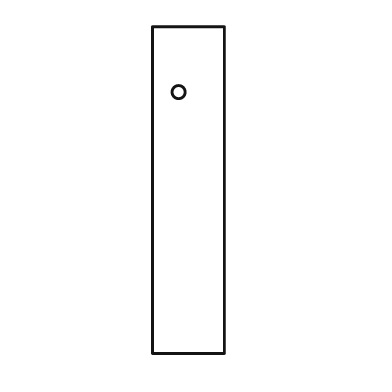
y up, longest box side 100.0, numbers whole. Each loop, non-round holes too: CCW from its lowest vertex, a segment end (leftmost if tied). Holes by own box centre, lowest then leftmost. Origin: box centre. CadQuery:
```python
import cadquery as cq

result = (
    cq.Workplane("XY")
    .moveTo(-11.0, -50.0)
    .lineTo(11.0, -50.0)
    .lineTo(11.0, 50.0)
    .lineTo(-11.0, 50.0)
    .close()
    .moveTo(-3.0, 30.0)
    .circle(2.0)
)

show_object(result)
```